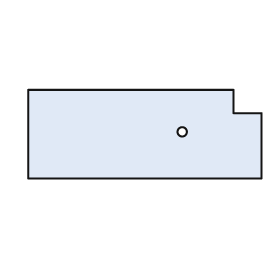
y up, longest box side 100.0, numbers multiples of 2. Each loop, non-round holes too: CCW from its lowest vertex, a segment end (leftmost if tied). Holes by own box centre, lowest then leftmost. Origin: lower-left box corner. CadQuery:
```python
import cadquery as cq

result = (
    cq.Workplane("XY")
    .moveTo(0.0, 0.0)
    .lineTo(100.0, 0.0)
    .lineTo(100.0, 28.0)
    .lineTo(88.0, 28.0)
    .lineTo(88.0, 38.0)
    .lineTo(0.0, 38.0)
    .close()
    .moveTo(66.0, 20.0)
    .circle(2.0)
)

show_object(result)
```